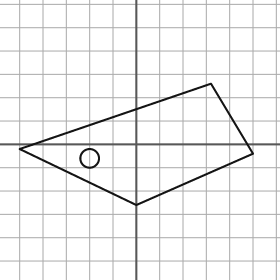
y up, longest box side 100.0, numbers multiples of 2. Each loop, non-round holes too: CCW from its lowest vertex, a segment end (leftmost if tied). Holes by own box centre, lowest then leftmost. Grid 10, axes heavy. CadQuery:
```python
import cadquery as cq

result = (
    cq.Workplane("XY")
    .moveTo(0.0, -26.0)
    .lineTo(50.0, -4.0)
    .lineTo(32.0, 26.0)
    .lineTo(-50.0, -2.0)
    .close()
    .moveTo(-20.0, -6.0)
    .circle(4.0)
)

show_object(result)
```